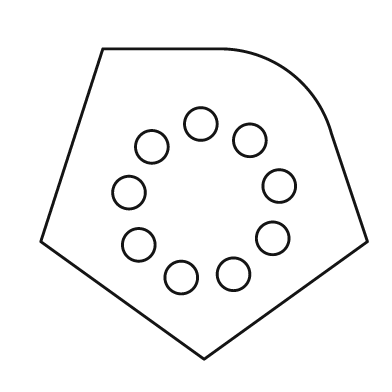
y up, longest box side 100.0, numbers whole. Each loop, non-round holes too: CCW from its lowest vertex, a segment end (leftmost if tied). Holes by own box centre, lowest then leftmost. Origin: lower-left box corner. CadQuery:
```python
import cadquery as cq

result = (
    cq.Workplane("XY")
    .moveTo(50.0, 0.0)
    .lineTo(100.0, 36.0)
    .lineTo(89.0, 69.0)
    .threePointArc((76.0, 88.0), (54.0, 95.0))
    .lineTo(19.0, 95.0)
    .lineTo(0.0, 36.0)
    .close()
    .moveTo(43.0, 25.0)
    .circle(5.0)
    .moveTo(59.0, 26.0)
    .circle(5.0)
    .moveTo(30.0, 35.0)
    .circle(5.0)
    .moveTo(71.0, 37.0)
    .circle(5.0)
    .moveTo(27.0, 51.0)
    .circle(5.0)
    .moveTo(73.0, 53.0)
    .circle(5.0)
    .moveTo(34.0, 65.0)
    .circle(5.0)
    .moveTo(64.0, 67.0)
    .circle(5.0)
    .moveTo(49.0, 72.0)
    .circle(5.0)
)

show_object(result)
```